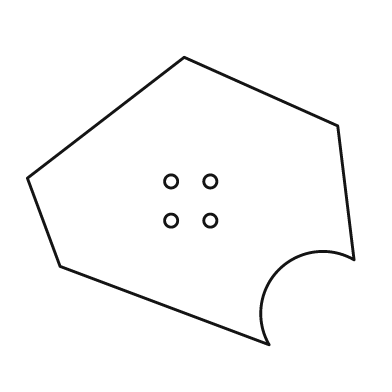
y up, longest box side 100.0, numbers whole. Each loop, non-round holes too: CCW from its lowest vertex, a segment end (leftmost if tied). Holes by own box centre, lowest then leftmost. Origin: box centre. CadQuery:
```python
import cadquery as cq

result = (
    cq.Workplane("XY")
    .moveTo(24.0, -44.0)
    .threePointArc((27.0, -21.0), (50.0, -18.0))
    .lineTo(45.0, 23.0)
    .lineTo(-2.0, 44.0)
    .lineTo(-50.0, 7.0)
    .lineTo(-40.0, -20.0)
    .close()
    .moveTo(-6.0, -6.0)
    .circle(2.0)
    .moveTo(6.0, -6.0)
    .circle(2.0)
    .moveTo(-6.0, 6.0)
    .circle(2.0)
    .moveTo(6.0, 6.0)
    .circle(2.0)
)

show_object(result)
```